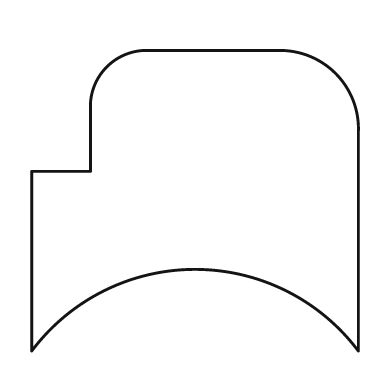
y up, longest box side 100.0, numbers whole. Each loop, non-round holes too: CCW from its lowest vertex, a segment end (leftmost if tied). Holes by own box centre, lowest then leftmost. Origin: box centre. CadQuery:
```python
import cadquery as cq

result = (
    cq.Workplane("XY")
    .moveTo(-50.0, -46.0)
    .threePointArc((0.0, -21.0), (50.0, -46.0))
    .lineTo(50.0, 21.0)
    .threePointArc((43.0, 39.0), (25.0, 46.0))
    .lineTo(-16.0, 46.0)
    .threePointArc((-27.0, 41.0), (-32.0, 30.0))
    .lineTo(-32.0, 9.0)
    .lineTo(-50.0, 9.0)
    .close()
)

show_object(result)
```